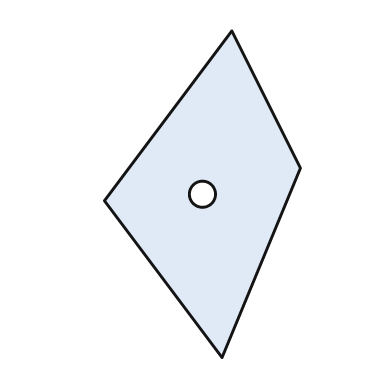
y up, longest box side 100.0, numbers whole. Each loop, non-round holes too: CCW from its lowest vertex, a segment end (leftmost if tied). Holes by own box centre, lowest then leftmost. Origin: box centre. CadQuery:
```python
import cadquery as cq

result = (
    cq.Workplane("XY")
    .moveTo(6.0, -50.0)
    .lineTo(30.0, 8.0)
    .lineTo(9.0, 50.0)
    .lineTo(-30.0, -2.0)
    .close()
    .moveTo(0.0, 0.0)
    .circle(4.0)
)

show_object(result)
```